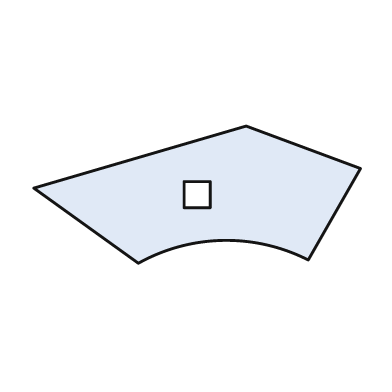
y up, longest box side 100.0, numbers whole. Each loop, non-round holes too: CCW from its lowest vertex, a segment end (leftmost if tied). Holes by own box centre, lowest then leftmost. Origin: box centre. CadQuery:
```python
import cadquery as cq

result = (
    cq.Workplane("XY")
    .moveTo(-18.0, -21.0)
    .threePointArc((8.0, -14.0), (34.0, -20.0))
    .lineTo(50.0, 8.0)
    .lineTo(15.0, 21.0)
    .lineTo(-50.0, 2.0)
    .close()
    .moveTo(-4.0, -4.0)
    .lineTo(4.0, -4.0)
    .lineTo(4.0, 4.0)
    .lineTo(-4.0, 4.0)
    .close()
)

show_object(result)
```